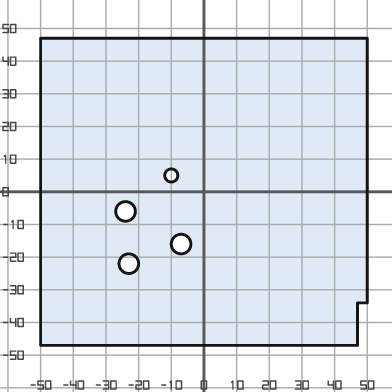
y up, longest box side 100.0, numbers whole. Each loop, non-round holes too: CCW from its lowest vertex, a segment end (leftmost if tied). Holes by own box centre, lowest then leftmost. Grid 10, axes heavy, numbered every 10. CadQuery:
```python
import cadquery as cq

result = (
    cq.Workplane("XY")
    .moveTo(-50.0, -47.0)
    .lineTo(47.0, -47.0)
    .lineTo(47.0, -34.0)
    .lineTo(50.0, -34.0)
    .lineTo(50.0, 47.0)
    .lineTo(-50.0, 47.0)
    .close()
    .moveTo(-23.0, -22.0)
    .circle(3.0)
    .moveTo(-7.0, -16.0)
    .circle(3.0)
    .moveTo(-24.0, -6.0)
    .circle(3.0)
    .moveTo(-10.0, 5.0)
    .circle(2.0)
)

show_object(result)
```